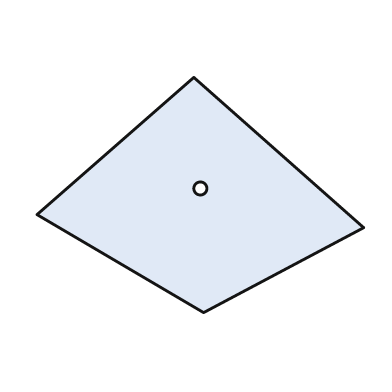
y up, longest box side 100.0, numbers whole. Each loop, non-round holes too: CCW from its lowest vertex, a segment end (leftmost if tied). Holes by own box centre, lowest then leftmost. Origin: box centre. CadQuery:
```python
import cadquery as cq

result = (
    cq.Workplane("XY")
    .moveTo(1.0, -36.0)
    .lineTo(50.0, -10.0)
    .lineTo(-2.0, 36.0)
    .lineTo(-50.0, -6.0)
    .close()
    .moveTo(0.0, 2.0)
    .circle(2.0)
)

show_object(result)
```